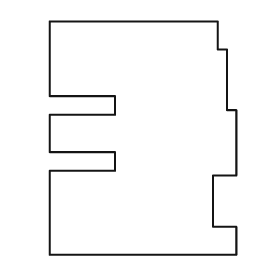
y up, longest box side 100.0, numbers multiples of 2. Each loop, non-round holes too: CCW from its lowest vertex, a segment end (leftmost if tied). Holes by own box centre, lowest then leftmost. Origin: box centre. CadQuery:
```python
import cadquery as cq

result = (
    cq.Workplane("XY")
    .moveTo(-40.0, -50.0)
    .lineTo(40.0, -50.0)
    .lineTo(40.0, -38.0)
    .lineTo(30.0, -38.0)
    .lineTo(30.0, -16.0)
    .lineTo(40.0, -16.0)
    .lineTo(40.0, 12.0)
    .lineTo(36.0, 12.0)
    .lineTo(36.0, 38.0)
    .lineTo(32.0, 38.0)
    .lineTo(32.0, 50.0)
    .lineTo(-40.0, 50.0)
    .lineTo(-40.0, 18.0)
    .lineTo(-12.0, 18.0)
    .lineTo(-12.0, 10.0)
    .lineTo(-40.0, 10.0)
    .lineTo(-40.0, -6.0)
    .lineTo(-12.0, -6.0)
    .lineTo(-12.0, -14.0)
    .lineTo(-40.0, -14.0)
    .close()
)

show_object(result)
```